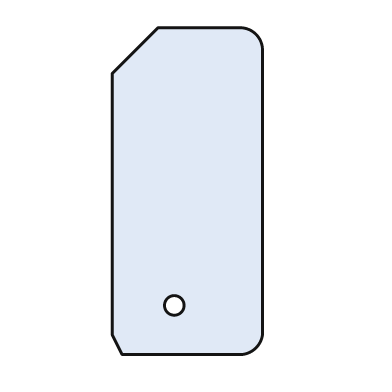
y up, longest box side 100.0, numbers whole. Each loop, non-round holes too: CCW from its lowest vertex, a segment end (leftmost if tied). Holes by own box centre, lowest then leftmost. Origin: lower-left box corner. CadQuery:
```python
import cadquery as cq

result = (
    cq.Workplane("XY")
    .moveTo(3.0, 0.0)
    .lineTo(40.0, 0.0)
    .threePointArc((44.0, 2.0), (46.0, 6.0))
    .lineTo(46.0, 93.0)
    .threePointArc((44.0, 98.0), (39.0, 100.0))
    .lineTo(14.0, 100.0)
    .lineTo(0.0, 86.0)
    .lineTo(0.0, 6.0)
    .close()
    .moveTo(19.0, 15.0)
    .circle(3.0)
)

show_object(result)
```